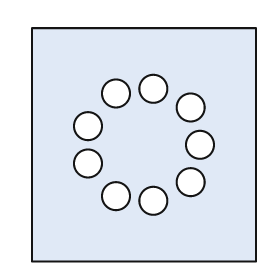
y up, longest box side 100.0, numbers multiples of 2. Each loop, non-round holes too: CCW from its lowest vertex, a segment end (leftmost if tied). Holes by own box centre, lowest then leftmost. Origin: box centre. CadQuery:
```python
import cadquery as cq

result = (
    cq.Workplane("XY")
    .moveTo(-48.0, -50.0)
    .lineTo(48.0, -50.0)
    .lineTo(48.0, 50.0)
    .lineTo(-48.0, 50.0)
    .close()
    .moveTo(4.0, -24.0)
    .circle(6.0)
    .moveTo(-12.0, -22.0)
    .circle(6.0)
    .moveTo(20.0, -16.0)
    .circle(6.0)
    .moveTo(-24.0, -8.0)
    .circle(6.0)
    .moveTo(24.0, 0.0)
    .circle(6.0)
    .moveTo(-24.0, 8.0)
    .circle(6.0)
    .moveTo(20.0, 16.0)
    .circle(6.0)
    .moveTo(-12.0, 22.0)
    .circle(6.0)
    .moveTo(4.0, 24.0)
    .circle(6.0)
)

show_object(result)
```